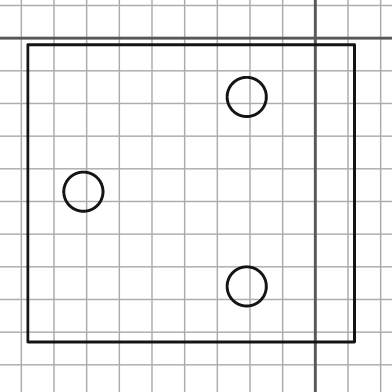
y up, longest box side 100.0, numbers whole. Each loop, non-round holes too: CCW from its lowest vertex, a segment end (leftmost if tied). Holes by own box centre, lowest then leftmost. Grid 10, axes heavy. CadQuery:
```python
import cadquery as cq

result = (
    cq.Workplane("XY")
    .moveTo(-88.0, -93.0)
    .lineTo(12.0, -93.0)
    .lineTo(12.0, -2.0)
    .lineTo(-88.0, -2.0)
    .close()
    .moveTo(-21.0, -76.0)
    .circle(6.0)
    .moveTo(-71.0, -47.0)
    .circle(6.0)
    .moveTo(-21.0, -18.0)
    .circle(6.0)
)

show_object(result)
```